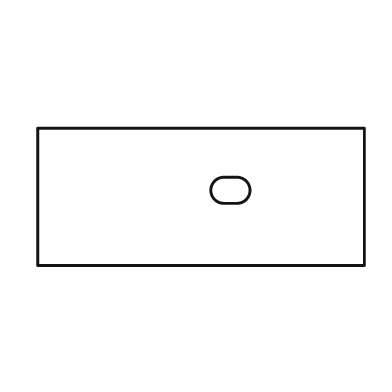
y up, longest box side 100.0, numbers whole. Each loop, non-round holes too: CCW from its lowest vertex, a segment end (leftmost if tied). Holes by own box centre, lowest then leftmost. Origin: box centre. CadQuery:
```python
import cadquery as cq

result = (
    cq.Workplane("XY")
    .moveTo(-50.0, -21.0)
    .lineTo(50.0, -21.0)
    .lineTo(50.0, 21.0)
    .lineTo(-50.0, 21.0)
    .close()
    .moveTo(7.0, -2.0)
    .lineTo(11.0, -2.0)
    .threePointArc((15.0, 2.0), (11.0, 6.0))
    .lineTo(7.0, 6.0)
    .threePointArc((3.0, 2.0), (7.0, -2.0))
    .close()
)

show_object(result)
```